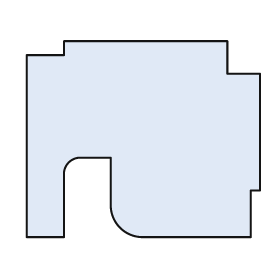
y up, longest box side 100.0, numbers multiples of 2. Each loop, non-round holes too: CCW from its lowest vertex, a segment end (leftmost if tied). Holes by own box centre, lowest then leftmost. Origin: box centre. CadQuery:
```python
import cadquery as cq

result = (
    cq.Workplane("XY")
    .moveTo(-50.0, -42.0)
    .lineTo(-34.0, -42.0)
    .lineTo(-34.0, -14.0)
    .threePointArc((-32.0, -10.0), (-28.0, -8.0))
    .lineTo(-14.0, -8.0)
    .lineTo(-14.0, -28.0)
    .threePointArc((-10.0, -38.0), (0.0, -42.0))
    .lineTo(46.0, -42.0)
    .lineTo(46.0, -22.0)
    .lineTo(50.0, -22.0)
    .lineTo(50.0, 28.0)
    .lineTo(36.0, 28.0)
    .lineTo(36.0, 42.0)
    .lineTo(-34.0, 42.0)
    .lineTo(-34.0, 36.0)
    .lineTo(-50.0, 36.0)
    .close()
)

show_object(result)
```